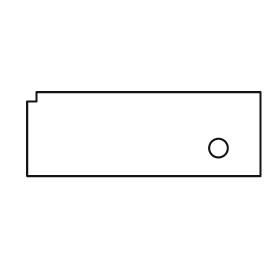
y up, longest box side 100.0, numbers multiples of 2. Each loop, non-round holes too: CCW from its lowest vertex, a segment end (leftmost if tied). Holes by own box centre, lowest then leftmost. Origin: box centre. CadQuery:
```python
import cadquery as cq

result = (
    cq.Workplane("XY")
    .moveTo(-50.0, -18.0)
    .lineTo(50.0, -18.0)
    .lineTo(50.0, 18.0)
    .lineTo(-46.0, 18.0)
    .lineTo(-46.0, 14.0)
    .lineTo(-50.0, 14.0)
    .close()
    .moveTo(32.0, -6.0)
    .circle(4.0)
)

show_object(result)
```